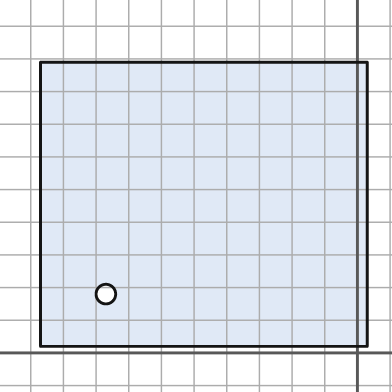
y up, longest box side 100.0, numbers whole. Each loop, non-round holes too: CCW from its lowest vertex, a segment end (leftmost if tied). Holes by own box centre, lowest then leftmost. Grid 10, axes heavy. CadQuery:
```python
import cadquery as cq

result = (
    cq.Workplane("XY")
    .moveTo(-97.0, 2.0)
    .lineTo(3.0, 2.0)
    .lineTo(3.0, 89.0)
    .lineTo(-97.0, 89.0)
    .close()
    .moveTo(-77.0, 18.0)
    .circle(3.0)
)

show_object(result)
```